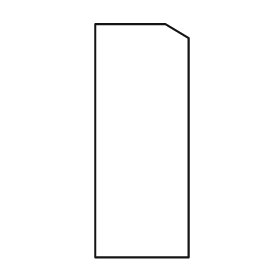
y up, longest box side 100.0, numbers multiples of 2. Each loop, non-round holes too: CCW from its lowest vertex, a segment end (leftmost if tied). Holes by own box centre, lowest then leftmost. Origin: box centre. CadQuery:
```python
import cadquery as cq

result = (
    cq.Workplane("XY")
    .moveTo(-20.0, -50.0)
    .lineTo(20.0, -50.0)
    .lineTo(20.0, 44.0)
    .lineTo(10.0, 50.0)
    .lineTo(-20.0, 50.0)
    .close()
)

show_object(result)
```